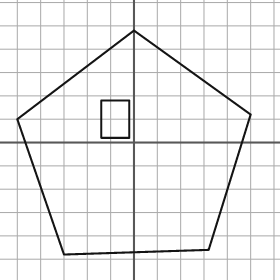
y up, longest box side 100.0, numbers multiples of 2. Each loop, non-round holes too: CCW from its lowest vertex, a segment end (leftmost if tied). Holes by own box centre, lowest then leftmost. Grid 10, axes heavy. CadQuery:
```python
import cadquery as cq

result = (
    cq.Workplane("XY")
    .moveTo(-30.0, -48.0)
    .lineTo(32.0, -46.0)
    .lineTo(50.0, 12.0)
    .lineTo(0.0, 48.0)
    .lineTo(-50.0, 10.0)
    .close()
    .moveTo(-14.0, 2.0)
    .lineTo(-2.0, 2.0)
    .lineTo(-2.0, 18.0)
    .lineTo(-14.0, 18.0)
    .close()
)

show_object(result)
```